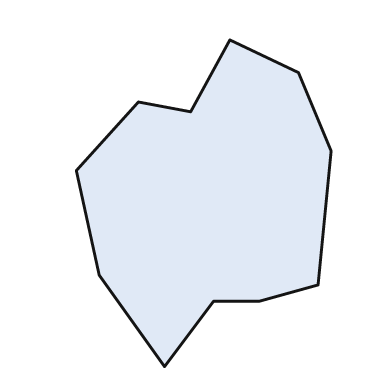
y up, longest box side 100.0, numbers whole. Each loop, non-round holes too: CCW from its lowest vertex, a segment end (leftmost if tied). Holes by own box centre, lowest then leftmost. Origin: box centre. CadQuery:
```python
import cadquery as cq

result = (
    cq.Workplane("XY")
    .moveTo(-12.0, -50.0)
    .lineTo(3.0, -30.0)
    .lineTo(17.0, -30.0)
    .lineTo(35.0, -25.0)
    .lineTo(39.0, 16.0)
    .lineTo(29.0, 40.0)
    .lineTo(8.0, 50.0)
    .lineTo(-4.0, 28.0)
    .lineTo(-20.0, 31.0)
    .lineTo(-39.0, 10.0)
    .lineTo(-32.0, -22.0)
    .close()
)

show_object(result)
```